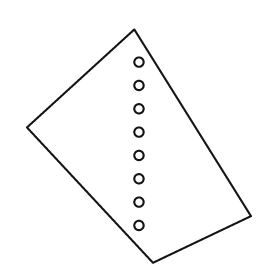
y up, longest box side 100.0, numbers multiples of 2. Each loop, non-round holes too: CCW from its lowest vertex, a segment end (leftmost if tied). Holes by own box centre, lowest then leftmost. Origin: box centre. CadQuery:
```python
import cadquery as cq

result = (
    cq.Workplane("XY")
    .moveTo(6.0, -50.0)
    .lineTo(48.0, -30.0)
    .lineTo(-2.0, 50.0)
    .lineTo(-48.0, 8.0)
    .close()
    .moveTo(0.0, -34.0)
    .circle(2.0)
    .moveTo(0.0, -24.0)
    .circle(2.0)
    .moveTo(0.0, -14.0)
    .circle(2.0)
    .moveTo(0.0, -4.0)
    .circle(2.0)
    .moveTo(0.0, 6.0)
    .circle(2.0)
    .moveTo(0.0, 16.0)
    .circle(2.0)
    .moveTo(0.0, 26.0)
    .circle(2.0)
    .moveTo(0.0, 36.0)
    .circle(2.0)
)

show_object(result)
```